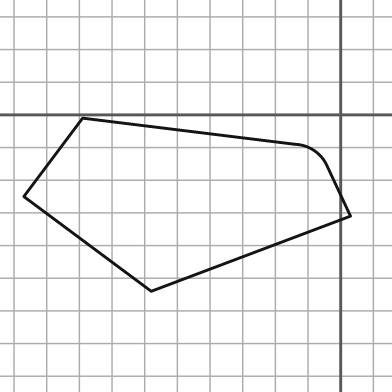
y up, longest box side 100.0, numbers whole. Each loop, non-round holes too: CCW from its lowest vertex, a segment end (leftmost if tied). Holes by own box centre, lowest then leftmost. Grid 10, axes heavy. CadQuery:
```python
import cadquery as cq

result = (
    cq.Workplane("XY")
    .moveTo(-58.0, -54.0)
    .lineTo(3.0, -31.0)
    .lineTo(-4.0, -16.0)
    .threePointArc((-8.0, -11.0), (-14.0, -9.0))
    .lineTo(-79.0, -1.0)
    .lineTo(-97.0, -25.0)
    .close()
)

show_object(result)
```